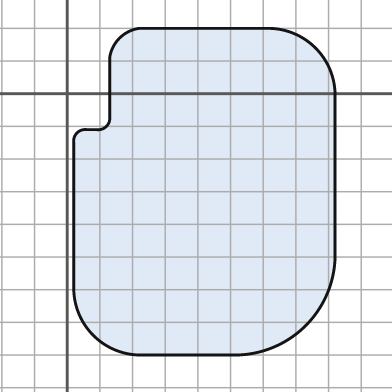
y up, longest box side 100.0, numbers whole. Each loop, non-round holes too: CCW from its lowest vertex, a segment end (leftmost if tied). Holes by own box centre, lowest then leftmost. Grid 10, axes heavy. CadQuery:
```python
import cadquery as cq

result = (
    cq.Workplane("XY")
    .moveTo(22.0, -80.0)
    .lineTo(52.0, -80.0)
    .threePointArc((73.0, -71.0), (82.0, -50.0))
    .lineTo(82.0, 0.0)
    .threePointArc((76.0, 14.0), (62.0, 20.0))
    .lineTo(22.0, 20.0)
    .threePointArc((16.0, 17.0), (13.0, 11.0))
    .lineTo(13.0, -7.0)
    .threePointArc((12.0, -10.0), (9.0, -11.0))
    .lineTo(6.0, -11.0)
    .threePointArc((3.0, -12.0), (2.0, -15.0))
    .lineTo(2.0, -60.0)
    .threePointArc((8.0, -74.0), (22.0, -80.0))
    .close()
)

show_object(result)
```